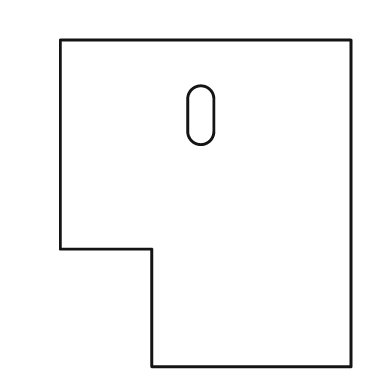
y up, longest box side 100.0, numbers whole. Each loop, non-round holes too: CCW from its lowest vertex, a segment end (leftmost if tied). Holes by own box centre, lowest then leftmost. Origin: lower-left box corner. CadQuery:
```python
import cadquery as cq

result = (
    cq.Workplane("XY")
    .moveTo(28.0, 0.0)
    .lineTo(89.0, 0.0)
    .lineTo(89.0, 100.0)
    .lineTo(0.0, 100.0)
    .lineTo(0.0, 36.0)
    .lineTo(28.0, 36.0)
    .close()
    .moveTo(39.0, 72.0)
    .threePointArc((43.0, 68.0), (47.0, 72.0))
    .lineTo(47.0, 82.0)
    .threePointArc((43.0, 86.0), (39.0, 82.0))
    .close()
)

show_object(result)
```